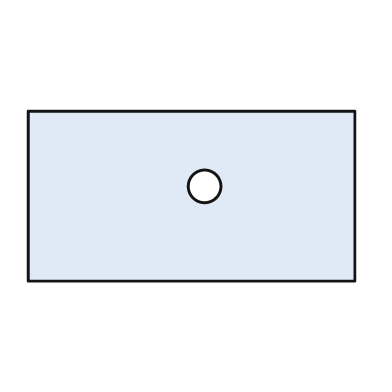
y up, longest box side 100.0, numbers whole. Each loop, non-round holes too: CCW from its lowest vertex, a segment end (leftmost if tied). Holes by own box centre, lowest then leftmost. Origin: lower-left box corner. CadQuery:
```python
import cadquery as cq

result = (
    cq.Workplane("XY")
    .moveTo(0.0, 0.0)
    .lineTo(100.0, 0.0)
    .lineTo(100.0, 52.0)
    .lineTo(0.0, 52.0)
    .close()
    .moveTo(54.0, 29.0)
    .circle(5.0)
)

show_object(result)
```